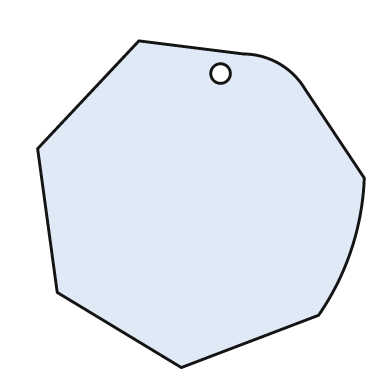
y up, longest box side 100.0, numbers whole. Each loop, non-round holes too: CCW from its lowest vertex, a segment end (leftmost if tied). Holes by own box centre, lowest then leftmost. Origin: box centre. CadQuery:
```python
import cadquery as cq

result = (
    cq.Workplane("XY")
    .moveTo(-6.0, -50.0)
    .lineTo(36.0, -34.0)
    .threePointArc((46.0, -14.0), (50.0, 8.0))
    .lineTo(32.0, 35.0)
    .threePointArc((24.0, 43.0), (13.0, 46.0))
    .lineTo(-19.0, 50.0)
    .lineTo(-50.0, 17.0)
    .lineTo(-44.0, -27.0)
    .close()
    .moveTo(6.0, 40.0)
    .circle(3.0)
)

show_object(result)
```